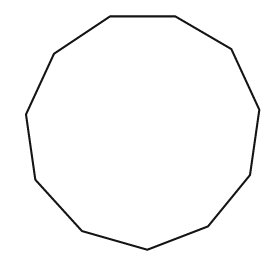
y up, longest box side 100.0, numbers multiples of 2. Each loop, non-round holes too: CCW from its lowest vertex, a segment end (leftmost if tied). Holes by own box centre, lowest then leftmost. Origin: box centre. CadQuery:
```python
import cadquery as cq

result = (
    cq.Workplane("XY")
    .moveTo(2.0, -50.0)
    .lineTo(28.0, -40.0)
    .lineTo(46.0, -18.0)
    .lineTo(50.0, 10.0)
    .lineTo(38.0, 36.0)
    .lineTo(14.0, 50.0)
    .lineTo(-14.0, 50.0)
    .lineTo(-38.0, 34.0)
    .lineTo(-50.0, 8.0)
    .lineTo(-46.0, -20.0)
    .lineTo(-26.0, -42.0)
    .close()
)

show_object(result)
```